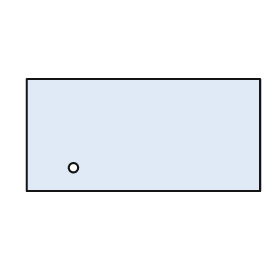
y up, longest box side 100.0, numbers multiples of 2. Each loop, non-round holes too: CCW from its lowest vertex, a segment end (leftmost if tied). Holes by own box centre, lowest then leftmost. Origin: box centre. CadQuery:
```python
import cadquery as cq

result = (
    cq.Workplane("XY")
    .moveTo(-50.0, -24.0)
    .lineTo(50.0, -24.0)
    .lineTo(50.0, 24.0)
    .lineTo(-50.0, 24.0)
    .close()
    .moveTo(-30.0, -14.0)
    .circle(2.0)
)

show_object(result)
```